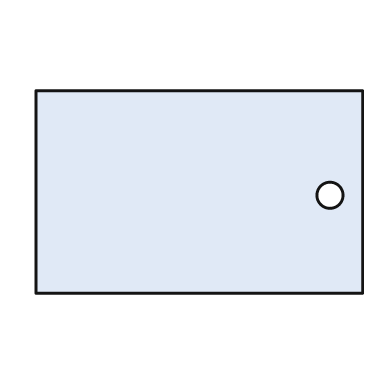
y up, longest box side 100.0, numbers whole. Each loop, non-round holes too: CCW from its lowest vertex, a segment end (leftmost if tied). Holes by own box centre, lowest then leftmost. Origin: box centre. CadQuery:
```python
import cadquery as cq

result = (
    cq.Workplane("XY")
    .moveTo(-50.0, -31.0)
    .lineTo(50.0, -31.0)
    .lineTo(50.0, 31.0)
    .lineTo(-50.0, 31.0)
    .close()
    .moveTo(40.0, -1.0)
    .circle(4.0)
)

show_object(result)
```